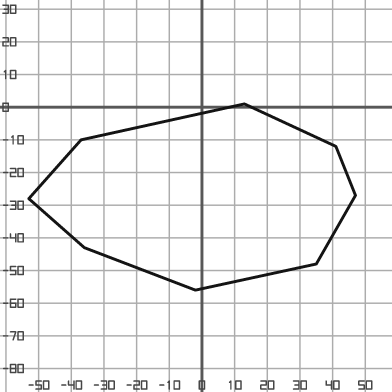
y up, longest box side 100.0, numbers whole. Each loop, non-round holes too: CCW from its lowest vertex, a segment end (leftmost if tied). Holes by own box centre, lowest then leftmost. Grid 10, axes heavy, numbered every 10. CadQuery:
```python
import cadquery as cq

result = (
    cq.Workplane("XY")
    .moveTo(-2.0, -56.0)
    .lineTo(35.0, -48.0)
    .lineTo(47.0, -27.0)
    .lineTo(41.0, -12.0)
    .lineTo(13.0, 1.0)
    .lineTo(-37.0, -10.0)
    .lineTo(-53.0, -28.0)
    .lineTo(-36.0, -43.0)
    .close()
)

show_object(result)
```